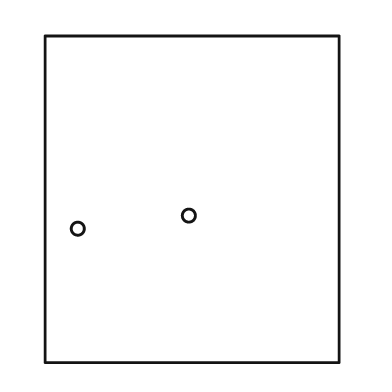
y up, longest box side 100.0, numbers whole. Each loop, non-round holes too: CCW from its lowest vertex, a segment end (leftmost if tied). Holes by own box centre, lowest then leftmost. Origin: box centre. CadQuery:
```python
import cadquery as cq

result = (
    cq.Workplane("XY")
    .moveTo(-45.0, -50.0)
    .lineTo(45.0, -50.0)
    .lineTo(45.0, 50.0)
    .lineTo(-45.0, 50.0)
    .close()
    .moveTo(-35.0, -9.0)
    .circle(2.0)
    .moveTo(-1.0, -5.0)
    .circle(2.0)
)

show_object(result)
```